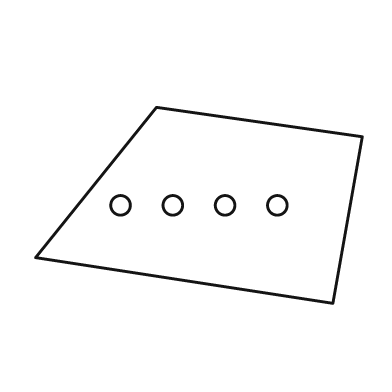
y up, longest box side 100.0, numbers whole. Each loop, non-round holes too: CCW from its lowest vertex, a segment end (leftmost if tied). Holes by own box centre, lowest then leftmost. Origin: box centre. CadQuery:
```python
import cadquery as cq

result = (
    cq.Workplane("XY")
    .moveTo(41.0, -30.0)
    .lineTo(50.0, 21.0)
    .lineTo(-13.0, 30.0)
    .lineTo(-50.0, -16.0)
    .close()
    .moveTo(-24.0, 0.0)
    .circle(3.0)
    .moveTo(-8.0, 0.0)
    .circle(3.0)
    .moveTo(8.0, 0.0)
    .circle(3.0)
    .moveTo(24.0, 0.0)
    .circle(3.0)
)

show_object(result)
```